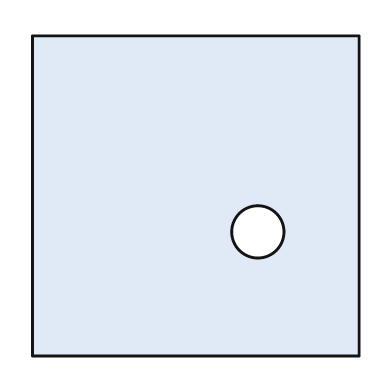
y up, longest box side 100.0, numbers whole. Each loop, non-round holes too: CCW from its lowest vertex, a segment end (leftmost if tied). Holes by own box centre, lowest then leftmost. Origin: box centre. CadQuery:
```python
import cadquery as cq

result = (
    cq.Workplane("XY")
    .moveTo(-50.0, -49.0)
    .lineTo(50.0, -49.0)
    .lineTo(50.0, 49.0)
    .lineTo(-50.0, 49.0)
    .close()
    .moveTo(19.0, -11.0)
    .circle(8.0)
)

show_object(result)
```